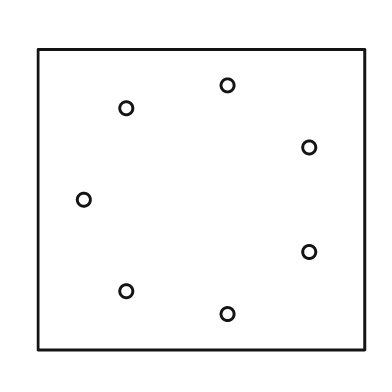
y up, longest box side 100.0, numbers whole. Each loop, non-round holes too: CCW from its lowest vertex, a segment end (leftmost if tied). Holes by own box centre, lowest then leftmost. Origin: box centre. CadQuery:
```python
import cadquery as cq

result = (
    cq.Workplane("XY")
    .moveTo(-50.0, -46.0)
    .lineTo(50.0, -46.0)
    .lineTo(50.0, 46.0)
    .lineTo(-50.0, 46.0)
    .close()
    .moveTo(8.0, -35.0)
    .circle(2.0)
    .moveTo(-23.0, -28.0)
    .circle(2.0)
    .moveTo(33.0, -16.0)
    .circle(2.0)
    .moveTo(-36.0, 0.0)
    .circle(2.0)
    .moveTo(33.0, 16.0)
    .circle(2.0)
    .moveTo(-23.0, 28.0)
    .circle(2.0)
    .moveTo(8.0, 35.0)
    .circle(2.0)
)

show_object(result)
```